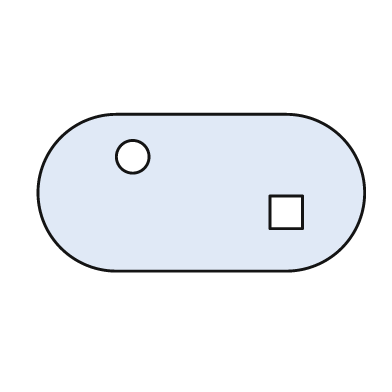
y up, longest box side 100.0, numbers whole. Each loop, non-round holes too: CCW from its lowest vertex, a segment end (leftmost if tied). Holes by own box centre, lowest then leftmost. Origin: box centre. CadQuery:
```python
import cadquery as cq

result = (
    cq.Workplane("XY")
    .moveTo(-26.0, -24.0)
    .lineTo(26.0, -24.0)
    .threePointArc((50.0, 0.0), (26.0, 24.0))
    .lineTo(-26.0, 24.0)
    .threePointArc((-50.0, 0.0), (-26.0, -24.0))
    .close()
    .moveTo(21.0, -11.0)
    .lineTo(31.0, -11.0)
    .lineTo(31.0, -1.0)
    .lineTo(21.0, -1.0)
    .close()
    .moveTo(-21.0, 11.0)
    .circle(5.0)
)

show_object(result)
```